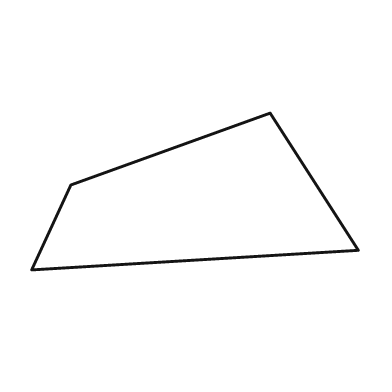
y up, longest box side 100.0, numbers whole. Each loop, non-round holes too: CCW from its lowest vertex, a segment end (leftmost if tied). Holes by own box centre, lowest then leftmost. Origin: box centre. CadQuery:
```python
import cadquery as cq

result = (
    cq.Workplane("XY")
    .moveTo(-50.0, -24.0)
    .lineTo(50.0, -18.0)
    .lineTo(23.0, 24.0)
    .lineTo(-38.0, 2.0)
    .close()
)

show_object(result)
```